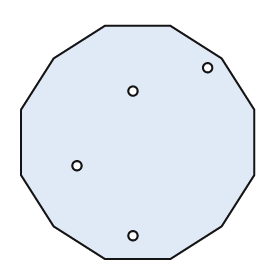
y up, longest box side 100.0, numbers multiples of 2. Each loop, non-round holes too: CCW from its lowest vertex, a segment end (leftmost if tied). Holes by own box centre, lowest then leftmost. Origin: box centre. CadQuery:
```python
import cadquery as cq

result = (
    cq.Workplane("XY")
    .moveTo(-14.0, -50.0)
    .lineTo(14.0, -50.0)
    .lineTo(36.0, -36.0)
    .lineTo(50.0, -14.0)
    .lineTo(50.0, 14.0)
    .lineTo(36.0, 36.0)
    .lineTo(14.0, 50.0)
    .lineTo(-14.0, 50.0)
    .lineTo(-36.0, 36.0)
    .lineTo(-50.0, 14.0)
    .lineTo(-50.0, -14.0)
    .lineTo(-36.0, -36.0)
    .close()
    .moveTo(-2.0, -40.0)
    .circle(2.0)
    .moveTo(-26.0, -10.0)
    .circle(2.0)
    .moveTo(-2.0, 22.0)
    .circle(2.0)
    .moveTo(30.0, 32.0)
    .circle(2.0)
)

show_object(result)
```